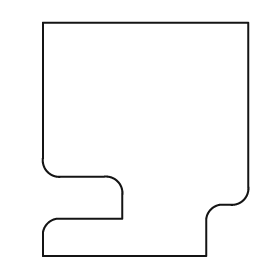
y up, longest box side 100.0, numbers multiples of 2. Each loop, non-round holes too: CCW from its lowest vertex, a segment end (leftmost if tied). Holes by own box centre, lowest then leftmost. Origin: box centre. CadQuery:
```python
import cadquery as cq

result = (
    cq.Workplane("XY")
    .moveTo(-44.0, -50.0)
    .lineTo(26.0, -50.0)
    .lineTo(26.0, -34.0)
    .threePointArc((28.0, -30.0), (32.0, -28.0))
    .lineTo(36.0, -28.0)
    .threePointArc((42.0, -26.0), (44.0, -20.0))
    .lineTo(44.0, 50.0)
    .lineTo(-44.0, 50.0)
    .lineTo(-44.0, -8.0)
    .threePointArc((-42.0, -14.0), (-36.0, -16.0))
    .lineTo(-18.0, -16.0)
    .threePointArc((-12.0, -18.0), (-10.0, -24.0))
    .lineTo(-10.0, -34.0)
    .lineTo(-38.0, -34.0)
    .threePointArc((-42.0, -36.0), (-44.0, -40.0))
    .close()
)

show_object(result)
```